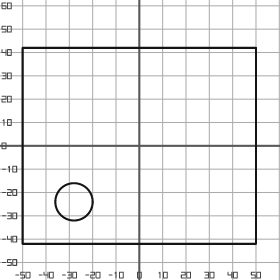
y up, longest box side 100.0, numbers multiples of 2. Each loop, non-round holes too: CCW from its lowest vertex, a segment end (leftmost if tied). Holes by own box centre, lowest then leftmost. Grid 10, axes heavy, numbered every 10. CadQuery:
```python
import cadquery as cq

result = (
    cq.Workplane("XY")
    .moveTo(-50.0, -42.0)
    .lineTo(50.0, -42.0)
    .lineTo(50.0, 42.0)
    .lineTo(-50.0, 42.0)
    .close()
    .moveTo(-28.0, -24.0)
    .circle(8.0)
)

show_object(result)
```